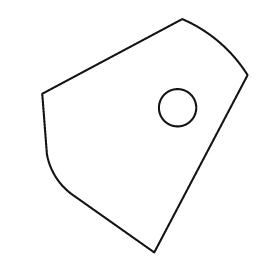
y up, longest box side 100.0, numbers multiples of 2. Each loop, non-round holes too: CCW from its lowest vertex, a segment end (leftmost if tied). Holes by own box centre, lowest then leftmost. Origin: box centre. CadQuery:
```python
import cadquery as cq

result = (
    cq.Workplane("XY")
    .moveTo(4.0, -50.0)
    .lineTo(44.0, 26.0)
    .threePointArc((32.0, 40.0), (16.0, 50.0))
    .lineTo(-44.0, 18.0)
    .lineTo(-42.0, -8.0)
    .threePointArc((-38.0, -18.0), (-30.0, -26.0))
    .close()
    .moveTo(14.0, 12.0)
    .circle(8.0)
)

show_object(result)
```